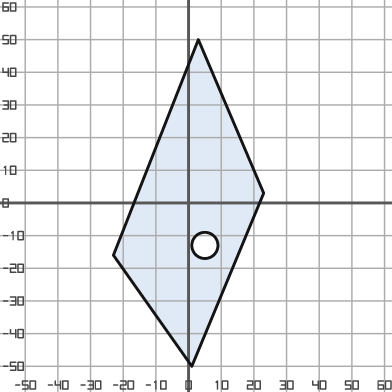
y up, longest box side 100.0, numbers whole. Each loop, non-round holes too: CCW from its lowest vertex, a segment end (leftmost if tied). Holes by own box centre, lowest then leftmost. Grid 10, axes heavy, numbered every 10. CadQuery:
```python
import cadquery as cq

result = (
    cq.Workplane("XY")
    .moveTo(1.0, -50.0)
    .lineTo(23.0, 3.0)
    .lineTo(3.0, 50.0)
    .lineTo(-23.0, -16.0)
    .close()
    .moveTo(5.0, -13.0)
    .circle(4.0)
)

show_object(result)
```